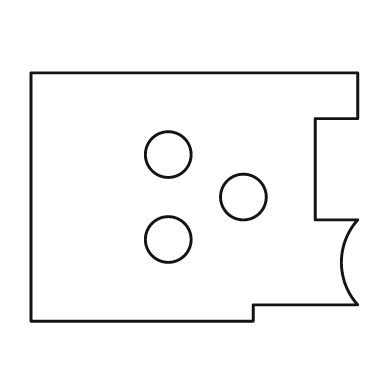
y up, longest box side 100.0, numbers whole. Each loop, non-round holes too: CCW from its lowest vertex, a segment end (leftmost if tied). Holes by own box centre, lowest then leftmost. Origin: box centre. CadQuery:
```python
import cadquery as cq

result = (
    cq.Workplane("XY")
    .moveTo(-50.0, -38.0)
    .lineTo(18.0, -38.0)
    .lineTo(18.0, -33.0)
    .lineTo(50.0, -33.0)
    .threePointArc((45.0, -20.0), (50.0, -7.0))
    .lineTo(37.0, -7.0)
    .lineTo(37.0, 24.0)
    .lineTo(50.0, 24.0)
    .lineTo(50.0, 38.0)
    .lineTo(-50.0, 38.0)
    .close()
    .moveTo(-8.0, -13.0)
    .circle(7.0)
    .moveTo(15.0, 0.0)
    .circle(7.0)
    .moveTo(-8.0, 13.0)
    .circle(7.0)
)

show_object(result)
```